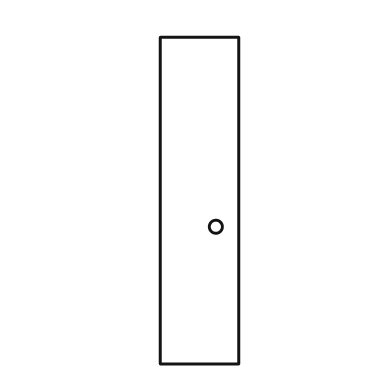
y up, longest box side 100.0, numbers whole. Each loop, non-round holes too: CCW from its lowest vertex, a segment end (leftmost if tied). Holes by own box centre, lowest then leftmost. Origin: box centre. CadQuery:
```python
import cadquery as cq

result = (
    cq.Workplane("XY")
    .moveTo(-12.0, -50.0)
    .lineTo(12.0, -50.0)
    .lineTo(12.0, 50.0)
    .lineTo(-12.0, 50.0)
    .close()
    .moveTo(5.0, -8.0)
    .circle(2.0)
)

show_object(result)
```